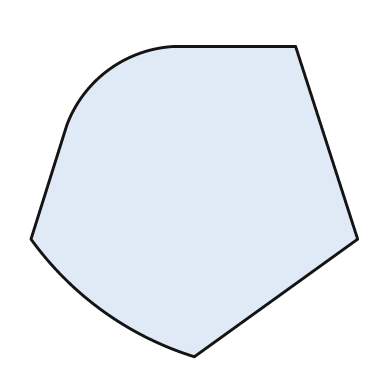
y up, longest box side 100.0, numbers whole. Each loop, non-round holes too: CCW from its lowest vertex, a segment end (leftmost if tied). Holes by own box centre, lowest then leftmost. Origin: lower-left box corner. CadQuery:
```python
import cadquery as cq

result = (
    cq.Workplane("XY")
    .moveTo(50.0, 0.0)
    .lineTo(100.0, 36.0)
    .lineTo(81.0, 95.0)
    .lineTo(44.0, 95.0)
    .threePointArc((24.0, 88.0), (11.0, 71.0))
    .lineTo(0.0, 36.0)
    .threePointArc((22.0, 14.0), (50.0, 0.0))
    .close()
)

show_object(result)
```